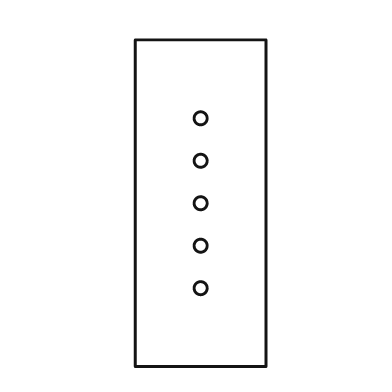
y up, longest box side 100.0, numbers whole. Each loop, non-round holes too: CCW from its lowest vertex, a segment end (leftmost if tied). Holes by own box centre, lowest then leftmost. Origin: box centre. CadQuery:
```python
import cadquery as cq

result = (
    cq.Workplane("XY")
    .moveTo(-20.0, -50.0)
    .lineTo(20.0, -50.0)
    .lineTo(20.0, 50.0)
    .lineTo(-20.0, 50.0)
    .close()
    .moveTo(0.0, -26.0)
    .circle(2.0)
    .moveTo(0.0, -13.0)
    .circle(2.0)
    .moveTo(0.0, 0.0)
    .circle(2.0)
    .moveTo(0.0, 13.0)
    .circle(2.0)
    .moveTo(0.0, 26.0)
    .circle(2.0)
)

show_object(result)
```